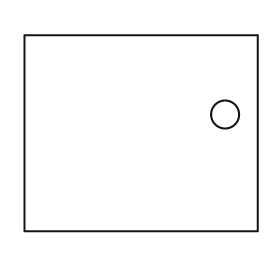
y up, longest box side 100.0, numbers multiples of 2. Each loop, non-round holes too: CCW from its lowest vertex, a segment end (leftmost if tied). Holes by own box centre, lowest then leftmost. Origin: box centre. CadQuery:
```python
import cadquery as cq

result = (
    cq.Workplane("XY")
    .moveTo(-50.0, -42.0)
    .lineTo(50.0, -42.0)
    .lineTo(50.0, 42.0)
    .lineTo(-50.0, 42.0)
    .close()
    .moveTo(36.0, 8.0)
    .circle(6.0)
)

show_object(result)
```